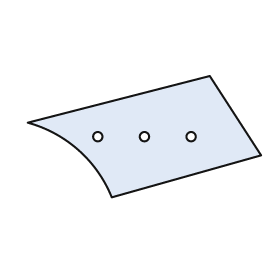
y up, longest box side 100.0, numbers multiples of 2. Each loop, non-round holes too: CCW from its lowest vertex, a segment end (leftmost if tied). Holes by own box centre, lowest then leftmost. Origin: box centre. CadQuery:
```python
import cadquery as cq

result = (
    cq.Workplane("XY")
    .moveTo(-14.0, -26.0)
    .lineTo(50.0, -8.0)
    .lineTo(28.0, 26.0)
    .lineTo(-50.0, 6.0)
    .threePointArc((-28.0, -6.0), (-14.0, -26.0))
    .close()
    .moveTo(-20.0, 0.0)
    .circle(2.0)
    .moveTo(0.0, 0.0)
    .circle(2.0)
    .moveTo(20.0, 0.0)
    .circle(2.0)
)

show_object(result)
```